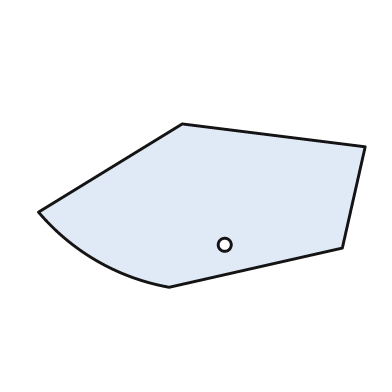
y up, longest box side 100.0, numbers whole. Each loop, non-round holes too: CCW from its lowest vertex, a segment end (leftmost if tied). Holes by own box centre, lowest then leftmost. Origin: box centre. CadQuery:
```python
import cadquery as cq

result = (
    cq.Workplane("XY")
    .moveTo(-10.0, -25.0)
    .lineTo(43.0, -13.0)
    .lineTo(50.0, 18.0)
    .lineTo(-6.0, 25.0)
    .lineTo(-50.0, -2.0)
    .threePointArc((-32.0, -17.0), (-10.0, -25.0))
    .close()
    .moveTo(7.0, -12.0)
    .circle(2.0)
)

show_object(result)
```